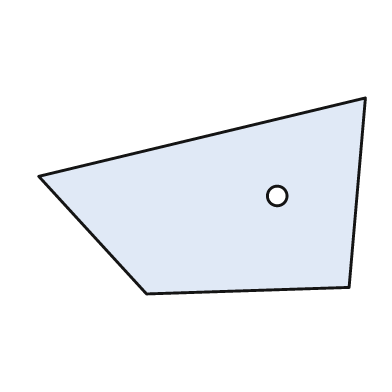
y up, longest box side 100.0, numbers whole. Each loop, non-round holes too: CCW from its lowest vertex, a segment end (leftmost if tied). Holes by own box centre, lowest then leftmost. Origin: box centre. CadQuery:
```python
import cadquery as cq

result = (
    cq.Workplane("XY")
    .moveTo(-17.0, -30.0)
    .lineTo(45.0, -28.0)
    .lineTo(50.0, 30.0)
    .lineTo(-50.0, 6.0)
    .close()
    .moveTo(23.0, 0.0)
    .circle(3.0)
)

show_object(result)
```